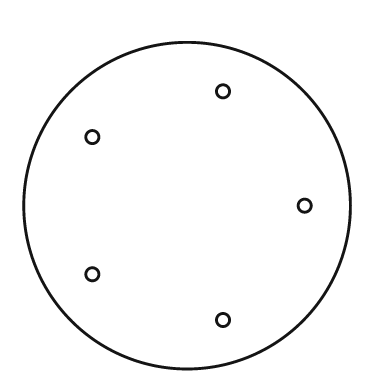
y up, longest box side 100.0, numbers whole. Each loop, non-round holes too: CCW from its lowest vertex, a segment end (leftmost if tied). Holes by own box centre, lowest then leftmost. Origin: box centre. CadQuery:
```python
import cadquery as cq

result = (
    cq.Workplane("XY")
    .moveTo(0.0, 0.0)
    .circle(50.0)
    .moveTo(11.0, -35.0)
    .circle(2.0)
    .moveTo(-29.0, -21.0)
    .circle(2.0)
    .moveTo(36.0, 0.0)
    .circle(2.0)
    .moveTo(-29.0, 21.0)
    .circle(2.0)
    .moveTo(11.0, 35.0)
    .circle(2.0)
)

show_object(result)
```